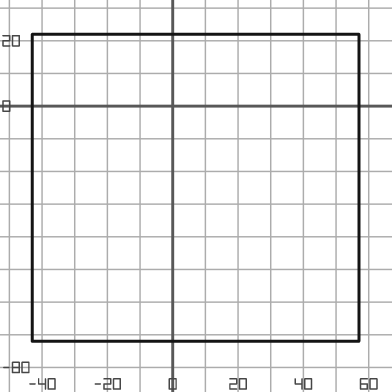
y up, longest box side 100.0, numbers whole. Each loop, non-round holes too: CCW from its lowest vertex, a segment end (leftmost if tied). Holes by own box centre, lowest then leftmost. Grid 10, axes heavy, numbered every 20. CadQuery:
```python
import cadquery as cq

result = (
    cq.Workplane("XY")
    .moveTo(-43.0, -72.0)
    .lineTo(57.0, -72.0)
    .lineTo(57.0, 22.0)
    .lineTo(-43.0, 22.0)
    .close()
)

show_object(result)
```